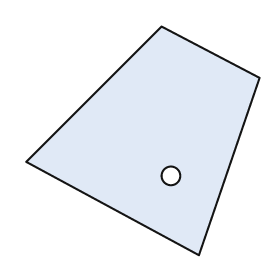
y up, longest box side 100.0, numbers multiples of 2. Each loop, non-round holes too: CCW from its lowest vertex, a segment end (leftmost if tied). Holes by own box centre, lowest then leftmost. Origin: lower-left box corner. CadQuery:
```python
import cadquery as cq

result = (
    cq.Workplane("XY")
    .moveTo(74.0, 0.0)
    .lineTo(100.0, 76.0)
    .lineTo(58.0, 98.0)
    .lineTo(0.0, 40.0)
    .close()
    .moveTo(62.0, 34.0)
    .circle(4.0)
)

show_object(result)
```